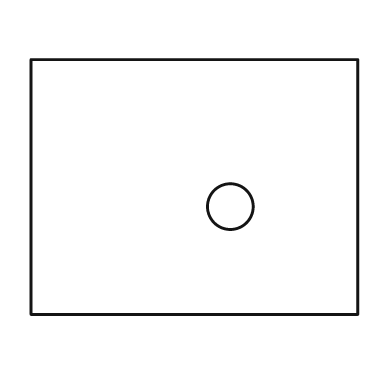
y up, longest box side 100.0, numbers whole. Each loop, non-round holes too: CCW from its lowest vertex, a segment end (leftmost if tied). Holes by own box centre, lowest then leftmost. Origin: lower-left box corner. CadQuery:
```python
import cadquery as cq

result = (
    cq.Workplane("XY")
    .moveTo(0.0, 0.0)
    .lineTo(100.0, 0.0)
    .lineTo(100.0, 78.0)
    .lineTo(0.0, 78.0)
    .close()
    .moveTo(61.0, 33.0)
    .circle(7.0)
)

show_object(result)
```